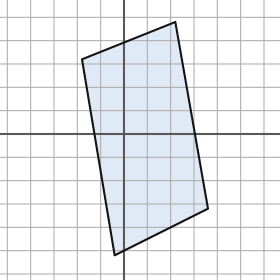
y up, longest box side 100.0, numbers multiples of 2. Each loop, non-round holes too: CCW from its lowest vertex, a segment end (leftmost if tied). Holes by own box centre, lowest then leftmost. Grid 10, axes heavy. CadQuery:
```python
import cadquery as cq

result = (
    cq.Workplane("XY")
    .moveTo(-4.0, -52.0)
    .lineTo(36.0, -32.0)
    .lineTo(22.0, 48.0)
    .lineTo(-18.0, 32.0)
    .close()
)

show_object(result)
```